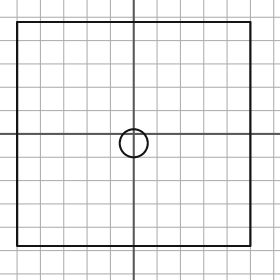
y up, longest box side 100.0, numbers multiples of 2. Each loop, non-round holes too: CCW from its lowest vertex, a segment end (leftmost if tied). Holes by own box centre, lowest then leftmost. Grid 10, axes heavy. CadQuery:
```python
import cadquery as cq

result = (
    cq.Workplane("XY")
    .moveTo(-50.0, -48.0)
    .lineTo(50.0, -48.0)
    .lineTo(50.0, 48.0)
    .lineTo(-50.0, 48.0)
    .close()
    .moveTo(0.0, -4.0)
    .circle(6.0)
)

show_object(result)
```